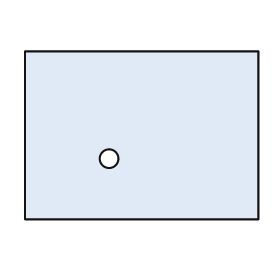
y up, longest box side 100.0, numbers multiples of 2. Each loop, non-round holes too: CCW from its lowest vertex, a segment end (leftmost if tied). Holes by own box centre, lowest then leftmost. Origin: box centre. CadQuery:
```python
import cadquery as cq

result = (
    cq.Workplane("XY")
    .moveTo(-50.0, -36.0)
    .lineTo(50.0, -36.0)
    .lineTo(50.0, 36.0)
    .lineTo(-50.0, 36.0)
    .close()
    .moveTo(-14.0, -10.0)
    .circle(4.0)
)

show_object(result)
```